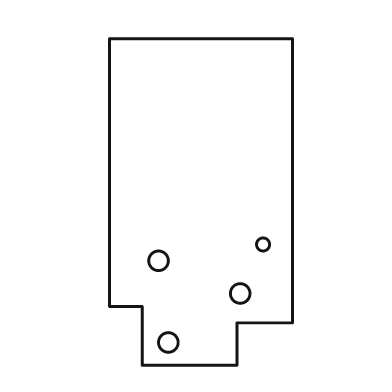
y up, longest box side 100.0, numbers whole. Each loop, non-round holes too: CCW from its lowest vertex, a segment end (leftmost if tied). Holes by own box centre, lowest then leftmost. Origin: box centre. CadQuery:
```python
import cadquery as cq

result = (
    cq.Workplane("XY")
    .moveTo(-18.0, -50.0)
    .lineTo(11.0, -50.0)
    .lineTo(11.0, -37.0)
    .lineTo(28.0, -37.0)
    .lineTo(28.0, 50.0)
    .lineTo(-28.0, 50.0)
    .lineTo(-28.0, -32.0)
    .lineTo(-18.0, -32.0)
    .close()
    .moveTo(-10.0, -43.0)
    .circle(3.0)
    .moveTo(12.0, -28.0)
    .circle(3.0)
    .moveTo(-13.0, -18.0)
    .circle(3.0)
    .moveTo(19.0, -13.0)
    .circle(2.0)
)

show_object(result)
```